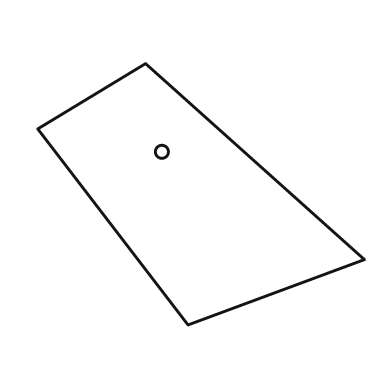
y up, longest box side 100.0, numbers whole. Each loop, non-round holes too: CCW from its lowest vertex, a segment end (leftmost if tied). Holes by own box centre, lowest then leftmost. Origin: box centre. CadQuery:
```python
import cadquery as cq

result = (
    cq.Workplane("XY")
    .moveTo(-4.0, -40.0)
    .lineTo(50.0, -20.0)
    .lineTo(-17.0, 40.0)
    .lineTo(-50.0, 20.0)
    .close()
    .moveTo(-12.0, 13.0)
    .circle(2.0)
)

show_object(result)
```